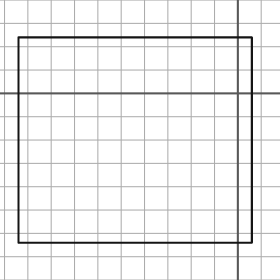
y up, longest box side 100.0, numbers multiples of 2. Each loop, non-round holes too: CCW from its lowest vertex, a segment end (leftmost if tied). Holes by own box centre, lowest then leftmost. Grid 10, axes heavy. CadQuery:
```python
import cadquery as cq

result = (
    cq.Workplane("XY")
    .moveTo(-94.0, -64.0)
    .lineTo(6.0, -64.0)
    .lineTo(6.0, 24.0)
    .lineTo(-94.0, 24.0)
    .close()
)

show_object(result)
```